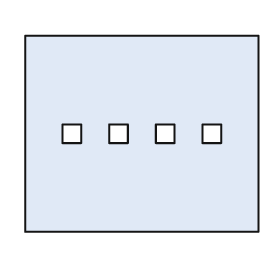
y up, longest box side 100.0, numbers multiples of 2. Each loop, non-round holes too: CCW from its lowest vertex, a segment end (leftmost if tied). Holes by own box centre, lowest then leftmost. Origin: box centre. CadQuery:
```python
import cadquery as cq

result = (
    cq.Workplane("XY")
    .moveTo(-50.0, -42.0)
    .lineTo(50.0, -42.0)
    .lineTo(50.0, 42.0)
    .lineTo(-50.0, 42.0)
    .close()
    .moveTo(-34.0, -4.0)
    .lineTo(-26.0, -4.0)
    .lineTo(-26.0, 4.0)
    .lineTo(-34.0, 4.0)
    .close()
    .moveTo(-14.0, -4.0)
    .lineTo(-6.0, -4.0)
    .lineTo(-6.0, 4.0)
    .lineTo(-14.0, 4.0)
    .close()
    .moveTo(6.0, -4.0)
    .lineTo(14.0, -4.0)
    .lineTo(14.0, 4.0)
    .lineTo(6.0, 4.0)
    .close()
    .moveTo(26.0, -4.0)
    .lineTo(34.0, -4.0)
    .lineTo(34.0, 4.0)
    .lineTo(26.0, 4.0)
    .close()
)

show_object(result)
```